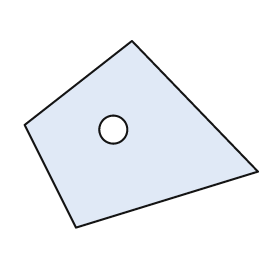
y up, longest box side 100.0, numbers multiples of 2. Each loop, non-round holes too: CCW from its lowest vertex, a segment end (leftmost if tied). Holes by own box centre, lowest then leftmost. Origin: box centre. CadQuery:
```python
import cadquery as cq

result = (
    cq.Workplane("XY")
    .moveTo(-28.0, -40.0)
    .lineTo(50.0, -16.0)
    .lineTo(-4.0, 40.0)
    .lineTo(-50.0, 4.0)
    .close()
    .moveTo(-12.0, 2.0)
    .circle(6.0)
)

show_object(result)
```